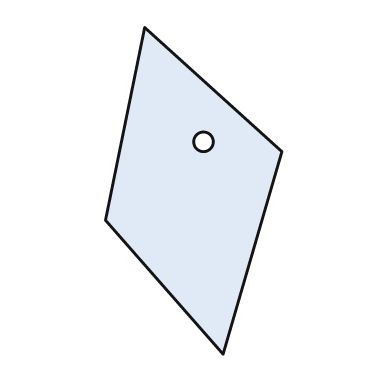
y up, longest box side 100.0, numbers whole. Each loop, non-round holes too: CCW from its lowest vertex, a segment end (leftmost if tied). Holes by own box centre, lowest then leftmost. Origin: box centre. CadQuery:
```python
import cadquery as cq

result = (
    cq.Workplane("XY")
    .moveTo(9.0, -50.0)
    .lineTo(27.0, 12.0)
    .lineTo(-15.0, 50.0)
    .lineTo(-27.0, -9.0)
    .close()
    .moveTo(3.0, 15.0)
    .circle(3.0)
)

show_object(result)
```